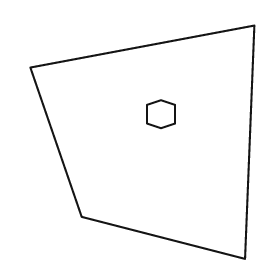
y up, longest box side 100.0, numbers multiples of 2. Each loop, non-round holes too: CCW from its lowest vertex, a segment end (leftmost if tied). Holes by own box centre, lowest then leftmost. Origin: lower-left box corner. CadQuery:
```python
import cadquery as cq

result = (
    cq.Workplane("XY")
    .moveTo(92.0, 0.0)
    .lineTo(96.0, 100.0)
    .lineTo(0.0, 82.0)
    .lineTo(22.0, 18.0)
    .close()
    .moveTo(56.0, 56.0)
    .lineTo(62.0, 58.0)
    .lineTo(62.0, 66.0)
    .lineTo(56.0, 68.0)
    .lineTo(50.0, 66.0)
    .lineTo(50.0, 58.0)
    .close()
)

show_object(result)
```